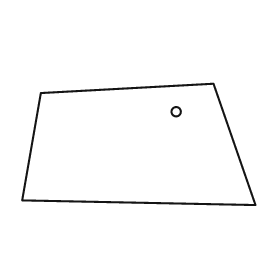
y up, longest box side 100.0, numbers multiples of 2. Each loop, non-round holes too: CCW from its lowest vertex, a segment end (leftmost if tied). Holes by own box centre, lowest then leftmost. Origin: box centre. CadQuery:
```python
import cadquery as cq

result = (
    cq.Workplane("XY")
    .moveTo(50.0, -26.0)
    .lineTo(32.0, 26.0)
    .lineTo(-42.0, 22.0)
    .lineTo(-50.0, -24.0)
    .close()
    .moveTo(16.0, 14.0)
    .circle(2.0)
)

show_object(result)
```